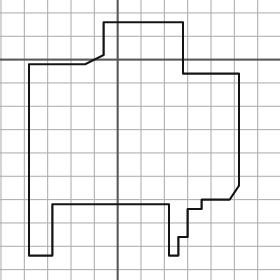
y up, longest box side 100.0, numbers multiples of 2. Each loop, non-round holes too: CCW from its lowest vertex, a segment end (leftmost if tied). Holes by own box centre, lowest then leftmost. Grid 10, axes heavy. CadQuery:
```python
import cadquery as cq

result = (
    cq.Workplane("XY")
    .moveTo(-38.0, -84.0)
    .lineTo(-28.0, -84.0)
    .lineTo(-28.0, -62.0)
    .lineTo(22.0, -62.0)
    .lineTo(22.0, -84.0)
    .lineTo(26.0, -84.0)
    .lineTo(26.0, -76.0)
    .lineTo(30.0, -76.0)
    .lineTo(30.0, -64.0)
    .lineTo(36.0, -64.0)
    .lineTo(36.0, -60.0)
    .lineTo(48.0, -60.0)
    .lineTo(52.0, -54.0)
    .lineTo(52.0, -6.0)
    .lineTo(28.0, -6.0)
    .lineTo(28.0, 16.0)
    .lineTo(-6.0, 16.0)
    .lineTo(-6.0, 2.0)
    .lineTo(-14.0, -2.0)
    .lineTo(-38.0, -2.0)
    .close()
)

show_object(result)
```